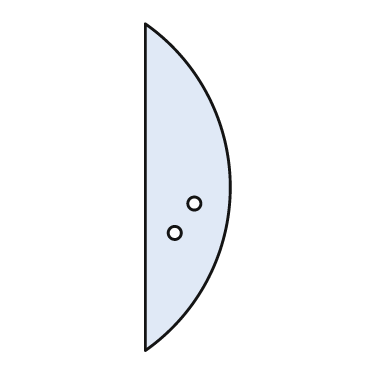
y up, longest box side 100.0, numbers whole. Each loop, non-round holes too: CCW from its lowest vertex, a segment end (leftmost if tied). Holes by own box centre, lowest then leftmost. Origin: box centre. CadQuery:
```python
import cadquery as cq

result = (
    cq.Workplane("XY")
    .moveTo(-13.0, -50.0)
    .threePointArc((13.0, 0.0), (-13.0, 50.0))
    .close()
    .moveTo(-4.0, -14.0)
    .circle(2.0)
    .moveTo(2.0, -5.0)
    .circle(2.0)
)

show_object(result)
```